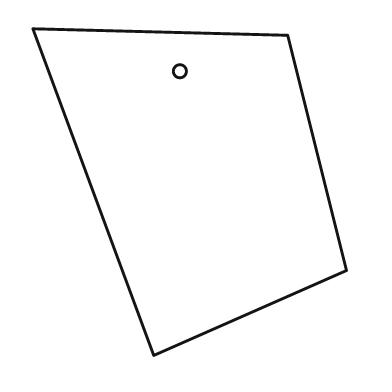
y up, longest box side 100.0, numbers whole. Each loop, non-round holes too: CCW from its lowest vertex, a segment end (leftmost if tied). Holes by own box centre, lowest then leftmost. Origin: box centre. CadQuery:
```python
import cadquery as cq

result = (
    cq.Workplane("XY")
    .moveTo(-11.0, -50.0)
    .lineTo(48.0, -24.0)
    .lineTo(30.0, 48.0)
    .lineTo(-48.0, 50.0)
    .close()
    .moveTo(-3.0, 37.0)
    .circle(2.0)
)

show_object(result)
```